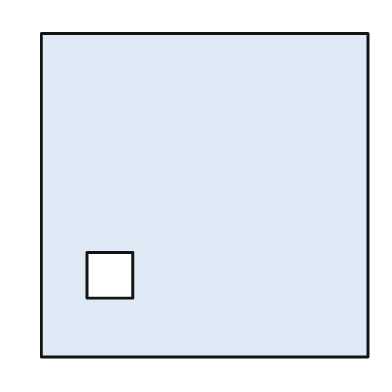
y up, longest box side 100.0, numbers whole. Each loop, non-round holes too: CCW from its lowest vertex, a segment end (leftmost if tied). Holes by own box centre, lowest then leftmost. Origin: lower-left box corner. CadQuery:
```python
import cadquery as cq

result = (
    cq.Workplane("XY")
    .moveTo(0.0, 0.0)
    .lineTo(100.0, 0.0)
    .lineTo(100.0, 99.0)
    .lineTo(0.0, 99.0)
    .close()
    .moveTo(14.0, 18.0)
    .lineTo(28.0, 18.0)
    .lineTo(28.0, 32.0)
    .lineTo(14.0, 32.0)
    .close()
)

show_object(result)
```